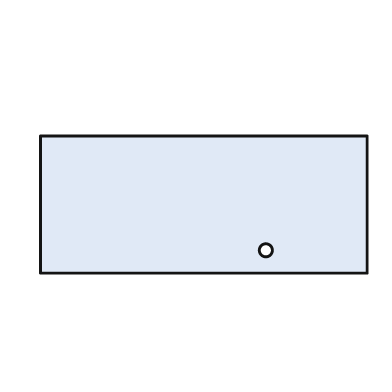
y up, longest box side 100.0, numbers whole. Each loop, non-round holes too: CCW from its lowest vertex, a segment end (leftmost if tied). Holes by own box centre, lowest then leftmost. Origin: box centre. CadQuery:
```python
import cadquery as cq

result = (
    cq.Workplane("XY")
    .moveTo(-50.0, -21.0)
    .lineTo(50.0, -21.0)
    .lineTo(50.0, 21.0)
    .lineTo(-50.0, 21.0)
    .close()
    .moveTo(19.0, -14.0)
    .circle(2.0)
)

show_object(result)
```